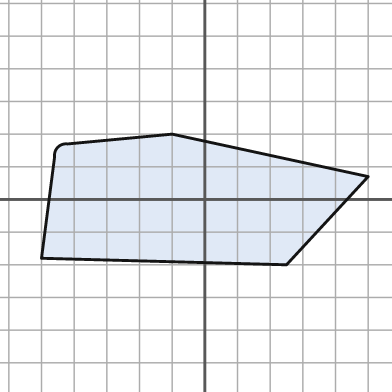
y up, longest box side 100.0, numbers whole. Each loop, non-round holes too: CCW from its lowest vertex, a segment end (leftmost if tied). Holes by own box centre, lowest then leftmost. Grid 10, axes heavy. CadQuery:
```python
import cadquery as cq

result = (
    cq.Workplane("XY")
    .moveTo(25.0, -20.0)
    .lineTo(50.0, 7.0)
    .lineTo(-10.0, 20.0)
    .lineTo(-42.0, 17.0)
    .threePointArc((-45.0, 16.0), (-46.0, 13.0))
    .lineTo(-50.0, -18.0)
    .close()
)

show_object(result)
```